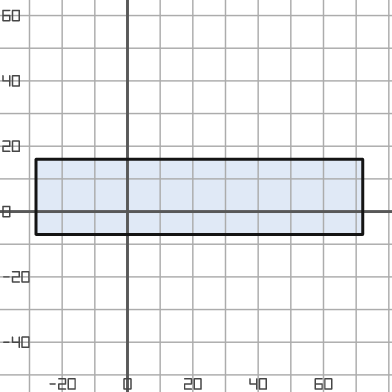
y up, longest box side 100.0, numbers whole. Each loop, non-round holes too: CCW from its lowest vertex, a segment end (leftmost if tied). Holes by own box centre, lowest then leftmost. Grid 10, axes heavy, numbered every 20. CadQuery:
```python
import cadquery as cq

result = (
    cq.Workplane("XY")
    .moveTo(-28.0, -7.0)
    .lineTo(72.0, -7.0)
    .lineTo(72.0, 16.0)
    .lineTo(-28.0, 16.0)
    .close()
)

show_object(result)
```